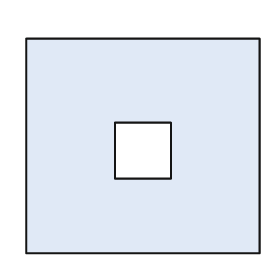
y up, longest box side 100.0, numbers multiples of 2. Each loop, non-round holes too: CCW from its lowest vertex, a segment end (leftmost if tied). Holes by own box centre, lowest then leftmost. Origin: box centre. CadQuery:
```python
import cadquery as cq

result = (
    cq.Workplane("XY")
    .moveTo(-50.0, -46.0)
    .lineTo(50.0, -46.0)
    .lineTo(50.0, 46.0)
    .lineTo(-50.0, 46.0)
    .close()
    .moveTo(-12.0, -14.0)
    .lineTo(12.0, -14.0)
    .lineTo(12.0, 10.0)
    .lineTo(-12.0, 10.0)
    .close()
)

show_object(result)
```